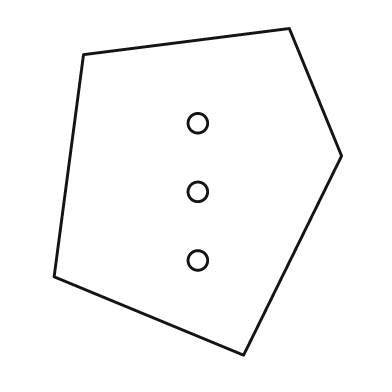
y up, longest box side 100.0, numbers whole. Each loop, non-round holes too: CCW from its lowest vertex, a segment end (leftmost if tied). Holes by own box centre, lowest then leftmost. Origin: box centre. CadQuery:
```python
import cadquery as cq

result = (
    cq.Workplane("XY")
    .moveTo(14.0, -50.0)
    .lineTo(44.0, 11.0)
    .lineTo(28.0, 50.0)
    .lineTo(-35.0, 42.0)
    .lineTo(-44.0, -26.0)
    .close()
    .moveTo(0.0, -21.0)
    .circle(3.0)
    .moveTo(0.0, 0.0)
    .circle(3.0)
    .moveTo(0.0, 21.0)
    .circle(3.0)
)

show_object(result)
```